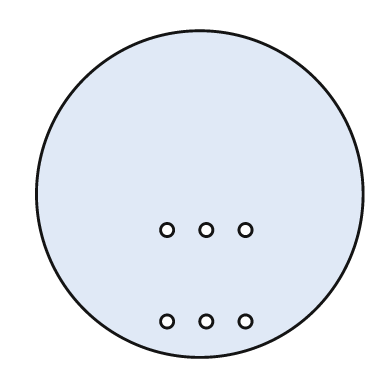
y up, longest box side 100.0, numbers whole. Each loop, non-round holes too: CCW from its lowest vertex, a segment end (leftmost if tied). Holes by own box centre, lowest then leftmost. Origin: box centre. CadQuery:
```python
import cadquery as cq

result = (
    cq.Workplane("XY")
    .moveTo(0.0, 0.0)
    .circle(50.0)
    .moveTo(-10.0, -39.0)
    .circle(2.0)
    .moveTo(2.0, -39.0)
    .circle(2.0)
    .moveTo(14.0, -39.0)
    .circle(2.0)
    .moveTo(-10.0, -11.0)
    .circle(2.0)
    .moveTo(2.0, -11.0)
    .circle(2.0)
    .moveTo(14.0, -11.0)
    .circle(2.0)
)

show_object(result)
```